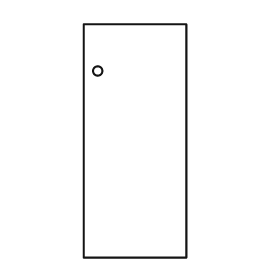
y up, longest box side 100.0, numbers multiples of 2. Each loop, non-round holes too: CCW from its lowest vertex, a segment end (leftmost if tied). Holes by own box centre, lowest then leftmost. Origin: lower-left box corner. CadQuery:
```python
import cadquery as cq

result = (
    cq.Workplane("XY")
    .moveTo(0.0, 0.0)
    .lineTo(44.0, 0.0)
    .lineTo(44.0, 100.0)
    .lineTo(0.0, 100.0)
    .close()
    .moveTo(6.0, 80.0)
    .circle(2.0)
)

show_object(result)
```